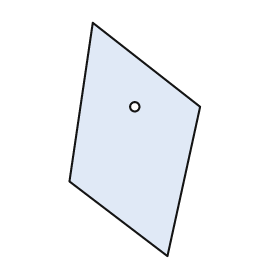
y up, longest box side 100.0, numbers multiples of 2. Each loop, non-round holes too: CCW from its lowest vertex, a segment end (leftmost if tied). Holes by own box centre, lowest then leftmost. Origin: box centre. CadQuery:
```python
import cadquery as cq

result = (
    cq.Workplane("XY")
    .moveTo(14.0, -50.0)
    .lineTo(28.0, 14.0)
    .lineTo(-18.0, 50.0)
    .lineTo(-28.0, -18.0)
    .close()
    .moveTo(0.0, 14.0)
    .circle(2.0)
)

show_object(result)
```